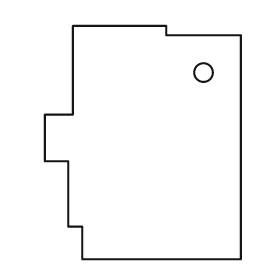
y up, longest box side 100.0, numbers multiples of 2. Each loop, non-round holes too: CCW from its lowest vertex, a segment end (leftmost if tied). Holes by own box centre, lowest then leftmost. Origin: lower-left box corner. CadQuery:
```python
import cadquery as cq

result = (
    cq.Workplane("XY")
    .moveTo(16.0, 0.0)
    .lineTo(84.0, 0.0)
    .lineTo(84.0, 96.0)
    .lineTo(52.0, 96.0)
    .lineTo(52.0, 100.0)
    .lineTo(12.0, 100.0)
    .lineTo(12.0, 62.0)
    .lineTo(0.0, 62.0)
    .lineTo(0.0, 42.0)
    .lineTo(10.0, 42.0)
    .lineTo(10.0, 14.0)
    .lineTo(16.0, 14.0)
    .close()
    .moveTo(68.0, 80.0)
    .circle(4.0)
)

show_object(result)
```